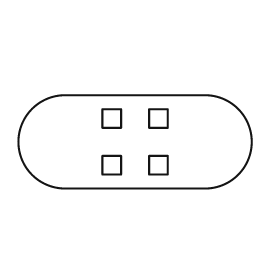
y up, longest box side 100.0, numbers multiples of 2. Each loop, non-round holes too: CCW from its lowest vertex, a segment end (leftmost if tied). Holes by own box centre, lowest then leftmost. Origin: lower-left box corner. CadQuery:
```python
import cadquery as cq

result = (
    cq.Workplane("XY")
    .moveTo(20.0, 0.0)
    .lineTo(80.0, 0.0)
    .threePointArc((100.0, 20.0), (80.0, 40.0))
    .lineTo(20.0, 40.0)
    .threePointArc((0.0, 20.0), (20.0, 0.0))
    .close()
    .moveTo(36.0, 6.0)
    .lineTo(44.0, 6.0)
    .lineTo(44.0, 14.0)
    .lineTo(36.0, 14.0)
    .close()
    .moveTo(56.0, 6.0)
    .lineTo(64.0, 6.0)
    .lineTo(64.0, 14.0)
    .lineTo(56.0, 14.0)
    .close()
    .moveTo(36.0, 26.0)
    .lineTo(44.0, 26.0)
    .lineTo(44.0, 34.0)
    .lineTo(36.0, 34.0)
    .close()
    .moveTo(56.0, 26.0)
    .lineTo(64.0, 26.0)
    .lineTo(64.0, 34.0)
    .lineTo(56.0, 34.0)
    .close()
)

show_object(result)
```